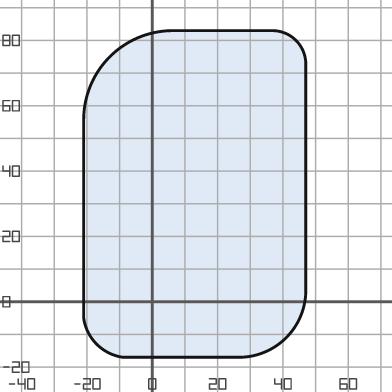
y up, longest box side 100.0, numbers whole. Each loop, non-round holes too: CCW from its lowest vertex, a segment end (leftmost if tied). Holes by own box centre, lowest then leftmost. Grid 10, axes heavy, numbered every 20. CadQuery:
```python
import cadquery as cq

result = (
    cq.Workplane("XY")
    .moveTo(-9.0, -17.0)
    .lineTo(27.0, -17.0)
    .threePointArc((41.0, -11.0), (47.0, 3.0))
    .lineTo(47.0, 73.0)
    .threePointArc((44.0, 80.0), (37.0, 83.0))
    .lineTo(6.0, 83.0)
    .threePointArc((-13.0, 75.0), (-21.0, 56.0))
    .lineTo(-21.0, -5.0)
    .threePointArc((-17.0, -13.0), (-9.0, -17.0))
    .close()
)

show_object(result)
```